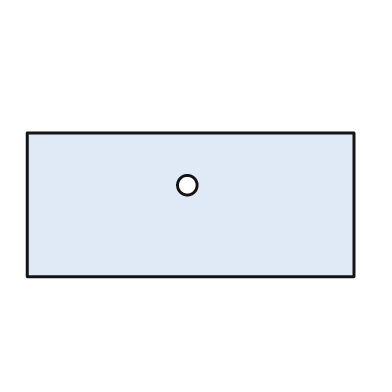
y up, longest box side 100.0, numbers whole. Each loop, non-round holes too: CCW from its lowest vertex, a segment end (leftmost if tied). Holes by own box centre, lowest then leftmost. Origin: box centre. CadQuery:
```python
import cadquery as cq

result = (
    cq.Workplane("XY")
    .moveTo(-50.0, -22.0)
    .lineTo(50.0, -22.0)
    .lineTo(50.0, 22.0)
    .lineTo(-50.0, 22.0)
    .close()
    .moveTo(-1.0, 6.0)
    .circle(3.0)
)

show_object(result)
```